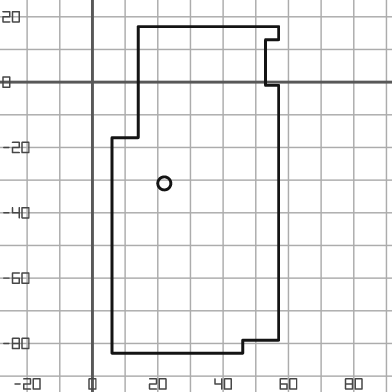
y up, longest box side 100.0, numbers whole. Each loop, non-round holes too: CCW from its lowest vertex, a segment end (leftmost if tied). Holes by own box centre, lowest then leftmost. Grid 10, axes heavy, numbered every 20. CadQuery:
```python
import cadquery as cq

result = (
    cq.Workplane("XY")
    .moveTo(6.0, -83.0)
    .lineTo(46.0, -83.0)
    .lineTo(46.0, -79.0)
    .lineTo(57.0, -79.0)
    .lineTo(57.0, -1.0)
    .lineTo(53.0, -1.0)
    .lineTo(53.0, 13.0)
    .lineTo(57.0, 13.0)
    .lineTo(57.0, 17.0)
    .lineTo(14.0, 17.0)
    .lineTo(14.0, -17.0)
    .lineTo(6.0, -17.0)
    .close()
    .moveTo(22.0, -31.0)
    .circle(2.0)
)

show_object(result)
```